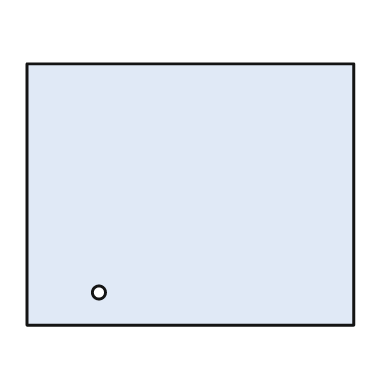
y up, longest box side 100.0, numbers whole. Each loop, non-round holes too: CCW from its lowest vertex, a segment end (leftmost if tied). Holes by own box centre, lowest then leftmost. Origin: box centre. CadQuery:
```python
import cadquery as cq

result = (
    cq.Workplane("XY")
    .moveTo(-50.0, -40.0)
    .lineTo(50.0, -40.0)
    .lineTo(50.0, 40.0)
    .lineTo(-50.0, 40.0)
    .close()
    .moveTo(-28.0, -30.0)
    .circle(2.0)
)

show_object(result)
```